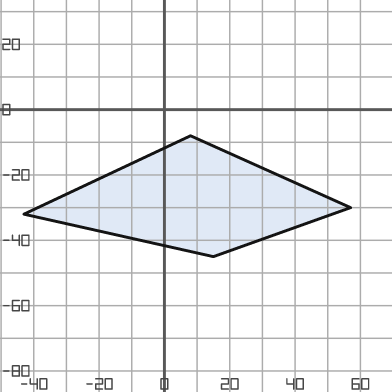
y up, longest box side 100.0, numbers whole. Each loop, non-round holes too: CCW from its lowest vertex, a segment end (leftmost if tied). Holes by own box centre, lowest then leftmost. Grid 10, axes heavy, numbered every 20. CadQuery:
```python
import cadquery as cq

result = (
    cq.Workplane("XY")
    .moveTo(15.0, -45.0)
    .lineTo(57.0, -30.0)
    .lineTo(8.0, -8.0)
    .lineTo(-43.0, -32.0)
    .close()
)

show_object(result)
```